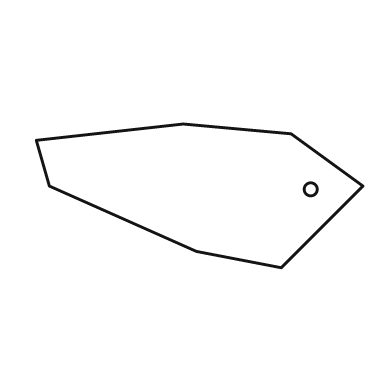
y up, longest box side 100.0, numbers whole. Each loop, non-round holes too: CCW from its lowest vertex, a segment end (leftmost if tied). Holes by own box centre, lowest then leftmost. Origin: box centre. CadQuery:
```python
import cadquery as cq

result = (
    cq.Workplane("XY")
    .moveTo(25.0, -22.0)
    .lineTo(50.0, 3.0)
    .lineTo(28.0, 19.0)
    .lineTo(-5.0, 22.0)
    .lineTo(-50.0, 17.0)
    .lineTo(-46.0, 3.0)
    .lineTo(-1.0, -17.0)
    .close()
    .moveTo(34.0, 2.0)
    .circle(2.0)
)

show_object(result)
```